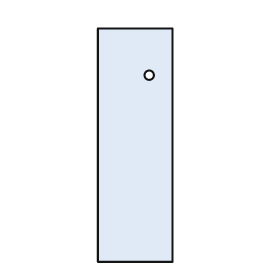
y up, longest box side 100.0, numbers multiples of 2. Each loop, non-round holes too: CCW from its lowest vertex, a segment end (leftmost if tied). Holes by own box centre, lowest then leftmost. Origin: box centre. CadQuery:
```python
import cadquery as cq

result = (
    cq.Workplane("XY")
    .moveTo(-16.0, -50.0)
    .lineTo(16.0, -50.0)
    .lineTo(16.0, 50.0)
    .lineTo(-16.0, 50.0)
    .close()
    .moveTo(6.0, 30.0)
    .circle(2.0)
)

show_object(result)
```